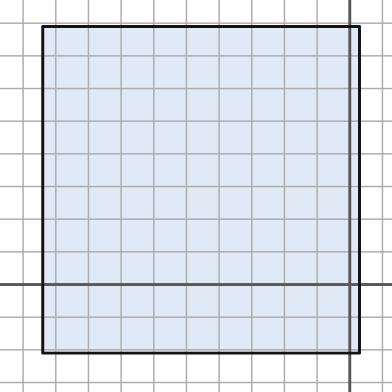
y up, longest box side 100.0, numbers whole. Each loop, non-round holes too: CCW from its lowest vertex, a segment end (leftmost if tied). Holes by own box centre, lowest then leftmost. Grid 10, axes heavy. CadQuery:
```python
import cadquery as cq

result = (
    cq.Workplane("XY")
    .moveTo(-94.0, -21.0)
    .lineTo(3.0, -21.0)
    .lineTo(3.0, 79.0)
    .lineTo(-94.0, 79.0)
    .close()
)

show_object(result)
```